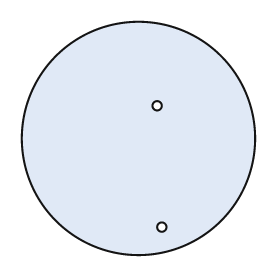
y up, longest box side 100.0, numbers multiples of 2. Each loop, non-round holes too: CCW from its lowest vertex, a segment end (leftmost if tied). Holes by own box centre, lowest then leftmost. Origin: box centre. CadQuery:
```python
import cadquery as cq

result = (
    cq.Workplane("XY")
    .moveTo(0.0, 0.0)
    .circle(50.0)
    .moveTo(10.0, -38.0)
    .circle(2.0)
    .moveTo(8.0, 14.0)
    .circle(2.0)
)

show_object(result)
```